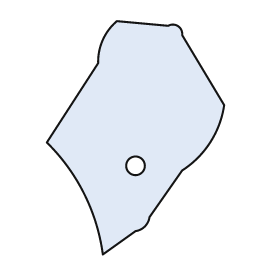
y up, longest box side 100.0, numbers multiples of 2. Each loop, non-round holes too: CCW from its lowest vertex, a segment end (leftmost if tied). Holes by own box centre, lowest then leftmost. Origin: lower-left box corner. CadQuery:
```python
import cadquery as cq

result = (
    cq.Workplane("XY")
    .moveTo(24.0, 0.0)
    .lineTo(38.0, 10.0)
    .threePointArc((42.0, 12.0), (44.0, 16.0))
    .lineTo(58.0, 36.0)
    .threePointArc((70.0, 48.0), (76.0, 64.0))
    .lineTo(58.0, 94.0)
    .threePointArc((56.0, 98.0), (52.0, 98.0))
    .lineTo(30.0, 100.0)
    .threePointArc((24.0, 92.0), (22.0, 82.0))
    .lineTo(0.0, 48.0)
    .threePointArc((16.0, 26.0), (24.0, 0.0))
    .close()
    .moveTo(38.0, 38.0)
    .circle(4.0)
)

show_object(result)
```